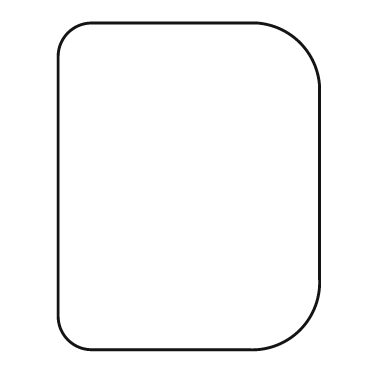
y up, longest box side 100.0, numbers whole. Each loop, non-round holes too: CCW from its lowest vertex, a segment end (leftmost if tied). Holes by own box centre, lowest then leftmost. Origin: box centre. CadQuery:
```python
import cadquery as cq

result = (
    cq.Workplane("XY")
    .moveTo(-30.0, -50.0)
    .lineTo(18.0, -50.0)
    .threePointArc((34.0, -44.0), (40.0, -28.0))
    .lineTo(40.0, 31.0)
    .threePointArc((34.0, 44.0), (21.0, 50.0))
    .lineTo(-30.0, 50.0)
    .threePointArc((-37.0, 47.0), (-40.0, 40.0))
    .lineTo(-40.0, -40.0)
    .threePointArc((-37.0, -47.0), (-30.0, -50.0))
    .close()
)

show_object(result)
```